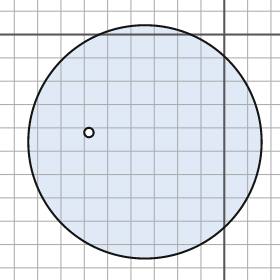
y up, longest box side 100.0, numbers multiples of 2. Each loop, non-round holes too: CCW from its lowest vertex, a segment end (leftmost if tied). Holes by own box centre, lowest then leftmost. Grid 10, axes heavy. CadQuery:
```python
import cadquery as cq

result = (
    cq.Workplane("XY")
    .moveTo(-34.0, -46.0)
    .circle(50.0)
    .moveTo(-58.0, -42.0)
    .circle(2.0)
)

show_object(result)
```